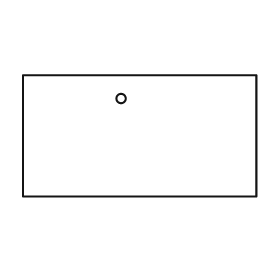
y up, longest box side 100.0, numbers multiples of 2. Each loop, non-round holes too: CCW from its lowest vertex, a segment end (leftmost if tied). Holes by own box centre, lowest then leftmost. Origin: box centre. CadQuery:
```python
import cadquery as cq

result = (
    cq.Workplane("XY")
    .moveTo(-50.0, -26.0)
    .lineTo(50.0, -26.0)
    .lineTo(50.0, 26.0)
    .lineTo(-50.0, 26.0)
    .close()
    .moveTo(-8.0, 16.0)
    .circle(2.0)
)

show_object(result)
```